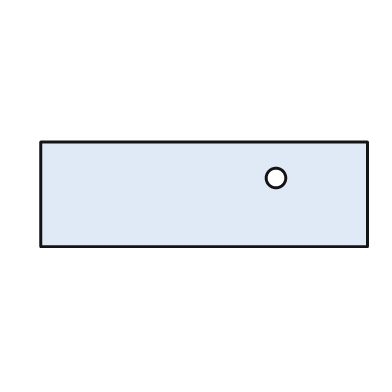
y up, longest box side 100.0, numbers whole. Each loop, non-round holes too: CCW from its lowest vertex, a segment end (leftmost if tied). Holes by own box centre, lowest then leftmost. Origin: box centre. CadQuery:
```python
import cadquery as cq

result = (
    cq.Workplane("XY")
    .moveTo(-50.0, -16.0)
    .lineTo(50.0, -16.0)
    .lineTo(50.0, 16.0)
    .lineTo(-50.0, 16.0)
    .close()
    .moveTo(22.0, 5.0)
    .circle(3.0)
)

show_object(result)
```